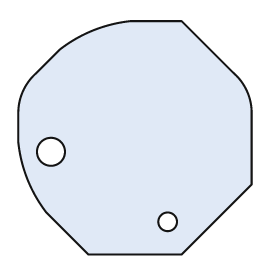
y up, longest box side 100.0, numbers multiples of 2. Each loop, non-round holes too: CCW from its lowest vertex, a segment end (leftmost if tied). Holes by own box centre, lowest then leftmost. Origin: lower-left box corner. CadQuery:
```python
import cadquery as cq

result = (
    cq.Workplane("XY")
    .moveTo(30.0, 0.0)
    .lineTo(70.0, 0.0)
    .lineTo(100.0, 30.0)
    .lineTo(100.0, 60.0)
    .threePointArc((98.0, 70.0), (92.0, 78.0))
    .lineTo(70.0, 100.0)
    .lineTo(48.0, 100.0)
    .threePointArc((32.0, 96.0), (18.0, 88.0))
    .lineTo(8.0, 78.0)
    .threePointArc((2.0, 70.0), (0.0, 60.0))
    .lineTo(0.0, 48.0)
    .threePointArc((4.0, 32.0), (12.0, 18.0))
    .close()
    .moveTo(64.0, 14.0)
    .circle(4.0)
    .moveTo(14.0, 44.0)
    .circle(6.0)
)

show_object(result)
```